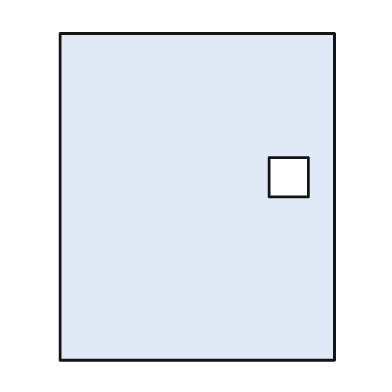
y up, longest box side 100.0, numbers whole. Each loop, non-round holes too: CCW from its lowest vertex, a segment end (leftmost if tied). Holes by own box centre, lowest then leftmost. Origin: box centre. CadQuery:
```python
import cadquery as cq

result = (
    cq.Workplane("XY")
    .moveTo(-42.0, -50.0)
    .lineTo(42.0, -50.0)
    .lineTo(42.0, 50.0)
    .lineTo(-42.0, 50.0)
    .close()
    .moveTo(22.0, 0.0)
    .lineTo(34.0, 0.0)
    .lineTo(34.0, 12.0)
    .lineTo(22.0, 12.0)
    .close()
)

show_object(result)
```